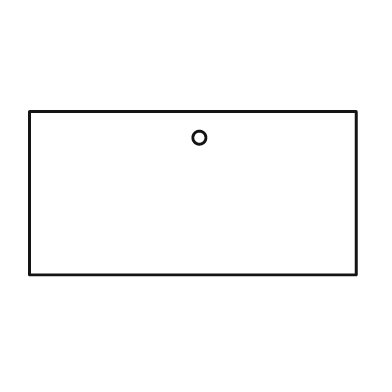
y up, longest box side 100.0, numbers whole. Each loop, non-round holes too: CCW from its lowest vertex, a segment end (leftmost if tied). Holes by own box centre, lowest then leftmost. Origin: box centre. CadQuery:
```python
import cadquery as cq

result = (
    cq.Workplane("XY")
    .moveTo(-50.0, -25.0)
    .lineTo(50.0, -25.0)
    .lineTo(50.0, 25.0)
    .lineTo(-50.0, 25.0)
    .close()
    .moveTo(2.0, 17.0)
    .circle(2.0)
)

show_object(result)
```